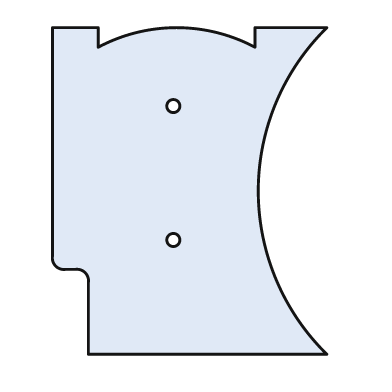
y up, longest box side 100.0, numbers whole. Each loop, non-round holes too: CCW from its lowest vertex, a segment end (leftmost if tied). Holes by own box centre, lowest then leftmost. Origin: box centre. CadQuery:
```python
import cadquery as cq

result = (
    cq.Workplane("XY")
    .moveTo(-31.0, -50.0)
    .lineTo(42.0, -50.0)
    .threePointArc((21.0, 0.0), (42.0, 50.0))
    .lineTo(20.0, 50.0)
    .lineTo(20.0, 44.0)
    .threePointArc((-4.0, 50.0), (-28.0, 44.0))
    .lineTo(-28.0, 50.0)
    .lineTo(-42.0, 50.0)
    .lineTo(-42.0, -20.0)
    .threePointArc((-41.0, -23.0), (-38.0, -24.0))
    .lineTo(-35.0, -24.0)
    .threePointArc((-32.0, -25.0), (-31.0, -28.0))
    .close()
    .moveTo(-5.0, -15.0)
    .circle(2.0)
    .moveTo(-5.0, 26.0)
    .circle(2.0)
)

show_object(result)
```